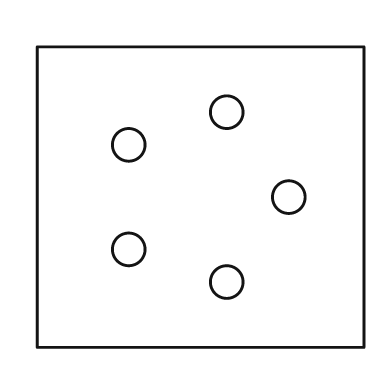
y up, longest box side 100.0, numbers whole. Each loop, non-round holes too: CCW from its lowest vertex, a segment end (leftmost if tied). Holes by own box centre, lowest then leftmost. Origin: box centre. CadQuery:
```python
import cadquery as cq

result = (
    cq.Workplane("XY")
    .moveTo(-50.0, -46.0)
    .lineTo(50.0, -46.0)
    .lineTo(50.0, 46.0)
    .lineTo(-50.0, 46.0)
    .close()
    .moveTo(8.0, -26.0)
    .circle(5.0)
    .moveTo(-22.0, -16.0)
    .circle(5.0)
    .moveTo(27.0, 0.0)
    .circle(5.0)
    .moveTo(-22.0, 16.0)
    .circle(5.0)
    .moveTo(8.0, 26.0)
    .circle(5.0)
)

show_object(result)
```